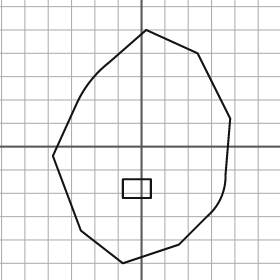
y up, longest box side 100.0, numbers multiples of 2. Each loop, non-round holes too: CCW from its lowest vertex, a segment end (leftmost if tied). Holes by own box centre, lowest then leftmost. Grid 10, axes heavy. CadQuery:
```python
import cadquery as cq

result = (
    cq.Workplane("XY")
    .moveTo(-8.0, -50.0)
    .lineTo(16.0, -42.0)
    .lineTo(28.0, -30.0)
    .threePointArc((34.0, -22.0), (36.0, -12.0))
    .lineTo(38.0, 12.0)
    .lineTo(24.0, 40.0)
    .lineTo(2.0, 50.0)
    .lineTo(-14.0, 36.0)
    .threePointArc((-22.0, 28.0), (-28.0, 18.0))
    .lineTo(-38.0, -4.0)
    .lineTo(-26.0, -36.0)
    .close()
    .moveTo(-8.0, -22.0)
    .lineTo(4.0, -22.0)
    .lineTo(4.0, -14.0)
    .lineTo(-8.0, -14.0)
    .close()
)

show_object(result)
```